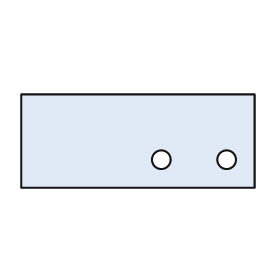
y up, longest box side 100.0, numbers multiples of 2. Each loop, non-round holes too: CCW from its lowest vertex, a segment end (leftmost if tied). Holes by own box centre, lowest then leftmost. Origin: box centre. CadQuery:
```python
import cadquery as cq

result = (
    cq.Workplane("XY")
    .moveTo(-50.0, -20.0)
    .lineTo(50.0, -20.0)
    .lineTo(50.0, 20.0)
    .lineTo(-50.0, 20.0)
    .close()
    .moveTo(10.0, -8.0)
    .circle(4.0)
    .moveTo(38.0, -8.0)
    .circle(4.0)
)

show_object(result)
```